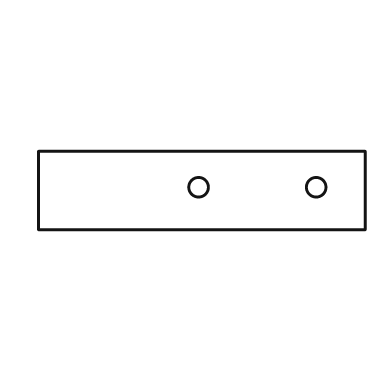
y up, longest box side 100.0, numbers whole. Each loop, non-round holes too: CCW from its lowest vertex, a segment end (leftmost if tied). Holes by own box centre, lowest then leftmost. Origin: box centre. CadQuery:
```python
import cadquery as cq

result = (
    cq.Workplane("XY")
    .moveTo(-50.0, -12.0)
    .lineTo(50.0, -12.0)
    .lineTo(50.0, 12.0)
    .lineTo(-50.0, 12.0)
    .close()
    .moveTo(-1.0, 1.0)
    .circle(3.0)
    .moveTo(35.0, 1.0)
    .circle(3.0)
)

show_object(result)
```